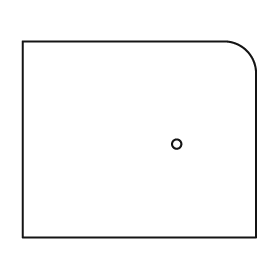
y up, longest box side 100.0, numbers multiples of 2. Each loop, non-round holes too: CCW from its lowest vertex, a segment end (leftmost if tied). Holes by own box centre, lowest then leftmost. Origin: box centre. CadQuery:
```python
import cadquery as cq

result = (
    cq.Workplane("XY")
    .moveTo(-50.0, -42.0)
    .lineTo(50.0, -42.0)
    .lineTo(50.0, 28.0)
    .threePointArc((46.0, 38.0), (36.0, 42.0))
    .lineTo(-50.0, 42.0)
    .close()
    .moveTo(16.0, -2.0)
    .circle(2.0)
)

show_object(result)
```